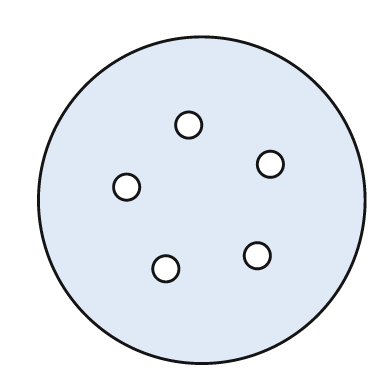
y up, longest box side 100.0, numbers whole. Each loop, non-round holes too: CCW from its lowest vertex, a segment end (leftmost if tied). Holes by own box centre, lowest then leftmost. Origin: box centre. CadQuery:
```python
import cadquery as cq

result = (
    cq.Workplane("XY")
    .moveTo(0.0, 0.0)
    .circle(50.0)
    .moveTo(-11.0, -21.0)
    .circle(4.0)
    .moveTo(17.0, -17.0)
    .circle(4.0)
    .moveTo(-23.0, 4.0)
    .circle(4.0)
    .moveTo(21.0, 11.0)
    .circle(4.0)
    .moveTo(-4.0, 23.0)
    .circle(4.0)
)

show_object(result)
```